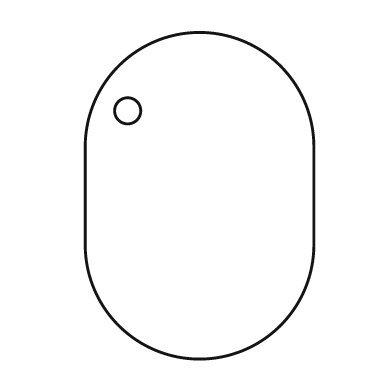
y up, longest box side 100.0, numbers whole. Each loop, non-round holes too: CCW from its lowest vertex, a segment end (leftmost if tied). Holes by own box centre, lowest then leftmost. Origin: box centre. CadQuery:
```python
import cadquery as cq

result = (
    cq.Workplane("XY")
    .moveTo(-35.0, -15.0)
    .threePointArc((0.0, -50.0), (35.0, -15.0))
    .lineTo(35.0, 15.0)
    .threePointArc((0.0, 50.0), (-35.0, 15.0))
    .close()
    .moveTo(-22.0, 26.0)
    .circle(4.0)
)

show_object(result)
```